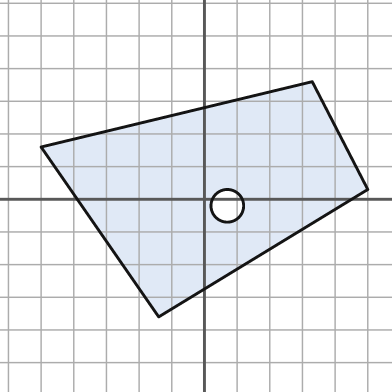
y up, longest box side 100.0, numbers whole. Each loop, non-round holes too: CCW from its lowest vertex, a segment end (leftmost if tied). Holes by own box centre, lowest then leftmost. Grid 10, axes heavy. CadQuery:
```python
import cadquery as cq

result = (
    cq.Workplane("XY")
    .moveTo(-14.0, -36.0)
    .lineTo(50.0, 3.0)
    .lineTo(33.0, 36.0)
    .lineTo(-50.0, 16.0)
    .close()
    .moveTo(7.0, -2.0)
    .circle(5.0)
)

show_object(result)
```